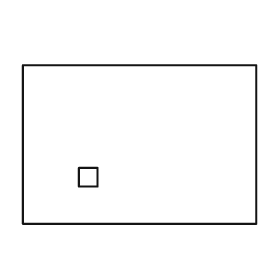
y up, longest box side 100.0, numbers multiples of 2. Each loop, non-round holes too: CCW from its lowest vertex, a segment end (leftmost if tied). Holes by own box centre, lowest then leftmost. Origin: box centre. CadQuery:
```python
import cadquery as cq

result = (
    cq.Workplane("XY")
    .moveTo(-50.0, -34.0)
    .lineTo(50.0, -34.0)
    .lineTo(50.0, 34.0)
    .lineTo(-50.0, 34.0)
    .close()
    .moveTo(-26.0, -18.0)
    .lineTo(-18.0, -18.0)
    .lineTo(-18.0, -10.0)
    .lineTo(-26.0, -10.0)
    .close()
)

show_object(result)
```